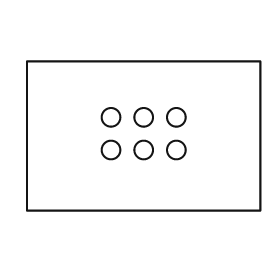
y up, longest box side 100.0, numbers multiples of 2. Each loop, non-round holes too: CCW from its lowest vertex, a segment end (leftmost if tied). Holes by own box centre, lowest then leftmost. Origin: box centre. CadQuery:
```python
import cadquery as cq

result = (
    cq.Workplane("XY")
    .moveTo(-50.0, -32.0)
    .lineTo(50.0, -32.0)
    .lineTo(50.0, 32.0)
    .lineTo(-50.0, 32.0)
    .close()
    .moveTo(-14.0, -6.0)
    .circle(4.0)
    .moveTo(0.0, -6.0)
    .circle(4.0)
    .moveTo(14.0, -6.0)
    .circle(4.0)
    .moveTo(-14.0, 8.0)
    .circle(4.0)
    .moveTo(0.0, 8.0)
    .circle(4.0)
    .moveTo(14.0, 8.0)
    .circle(4.0)
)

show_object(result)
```